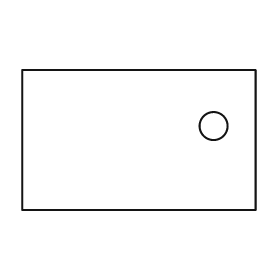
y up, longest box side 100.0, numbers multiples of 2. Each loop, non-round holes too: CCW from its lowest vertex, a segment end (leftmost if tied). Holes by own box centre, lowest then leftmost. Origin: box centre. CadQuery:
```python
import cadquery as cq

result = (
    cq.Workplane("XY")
    .moveTo(-50.0, -30.0)
    .lineTo(50.0, -30.0)
    .lineTo(50.0, 30.0)
    .lineTo(-50.0, 30.0)
    .close()
    .moveTo(32.0, 6.0)
    .circle(6.0)
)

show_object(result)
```